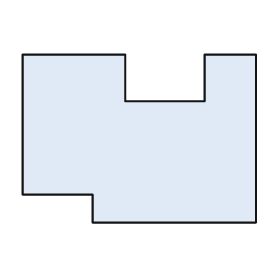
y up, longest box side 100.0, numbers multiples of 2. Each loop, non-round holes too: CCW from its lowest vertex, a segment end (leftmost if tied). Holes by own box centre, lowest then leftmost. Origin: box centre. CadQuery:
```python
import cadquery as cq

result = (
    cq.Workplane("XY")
    .moveTo(-20.0, -36.0)
    .lineTo(50.0, -36.0)
    .lineTo(50.0, 36.0)
    .lineTo(28.0, 36.0)
    .lineTo(28.0, 16.0)
    .lineTo(-6.0, 16.0)
    .lineTo(-6.0, 36.0)
    .lineTo(-50.0, 36.0)
    .lineTo(-50.0, -24.0)
    .lineTo(-20.0, -24.0)
    .close()
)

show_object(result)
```